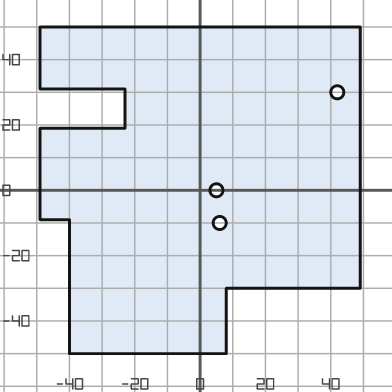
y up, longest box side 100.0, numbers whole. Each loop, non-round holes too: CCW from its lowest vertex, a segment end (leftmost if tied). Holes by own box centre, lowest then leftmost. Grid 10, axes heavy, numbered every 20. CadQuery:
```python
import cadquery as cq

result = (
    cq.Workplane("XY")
    .moveTo(-40.0, -50.0)
    .lineTo(8.0, -50.0)
    .lineTo(8.0, -30.0)
    .lineTo(49.0, -30.0)
    .lineTo(49.0, 50.0)
    .lineTo(-49.0, 50.0)
    .lineTo(-49.0, 31.0)
    .lineTo(-23.0, 31.0)
    .lineTo(-23.0, 19.0)
    .lineTo(-49.0, 19.0)
    .lineTo(-49.0, -9.0)
    .lineTo(-40.0, -9.0)
    .close()
    .moveTo(6.0, -10.0)
    .circle(2.0)
    .moveTo(5.0, 0.0)
    .circle(2.0)
    .moveTo(42.0, 30.0)
    .circle(2.0)
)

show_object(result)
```